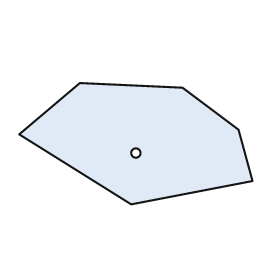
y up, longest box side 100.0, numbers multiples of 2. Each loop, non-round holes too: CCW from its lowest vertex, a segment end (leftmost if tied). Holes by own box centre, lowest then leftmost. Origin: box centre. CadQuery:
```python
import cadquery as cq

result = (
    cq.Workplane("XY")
    .moveTo(-2.0, -26.0)
    .lineTo(50.0, -16.0)
    .lineTo(44.0, 6.0)
    .lineTo(20.0, 24.0)
    .lineTo(-24.0, 26.0)
    .lineTo(-50.0, 4.0)
    .close()
    .moveTo(0.0, -4.0)
    .circle(2.0)
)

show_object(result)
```